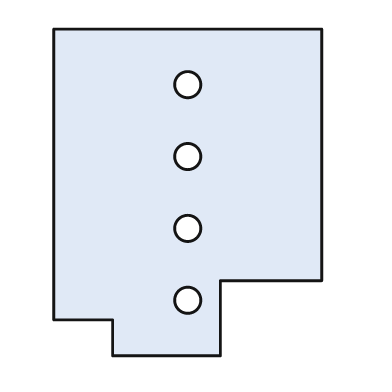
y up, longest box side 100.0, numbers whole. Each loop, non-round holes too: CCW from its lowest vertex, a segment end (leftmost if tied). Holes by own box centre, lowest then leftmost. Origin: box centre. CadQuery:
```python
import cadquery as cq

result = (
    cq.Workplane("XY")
    .moveTo(-23.0, -50.0)
    .lineTo(10.0, -50.0)
    .lineTo(10.0, -27.0)
    .lineTo(41.0, -27.0)
    .lineTo(41.0, 50.0)
    .lineTo(-41.0, 50.0)
    .lineTo(-41.0, -39.0)
    .lineTo(-23.0, -39.0)
    .close()
    .moveTo(0.0, -33.0)
    .circle(4.0)
    .moveTo(0.0, -11.0)
    .circle(4.0)
    .moveTo(0.0, 11.0)
    .circle(4.0)
    .moveTo(0.0, 33.0)
    .circle(4.0)
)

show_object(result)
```